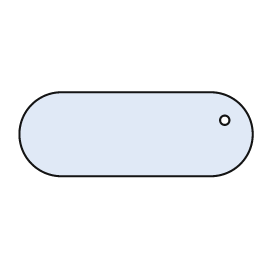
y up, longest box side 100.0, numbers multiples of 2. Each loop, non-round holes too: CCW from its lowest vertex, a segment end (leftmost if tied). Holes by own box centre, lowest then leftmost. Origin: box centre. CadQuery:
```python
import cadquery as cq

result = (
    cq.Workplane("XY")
    .moveTo(-32.0, -18.0)
    .lineTo(32.0, -18.0)
    .threePointArc((50.0, 0.0), (32.0, 18.0))
    .lineTo(-32.0, 18.0)
    .threePointArc((-50.0, 0.0), (-32.0, -18.0))
    .close()
    .moveTo(38.0, 6.0)
    .circle(2.0)
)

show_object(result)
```